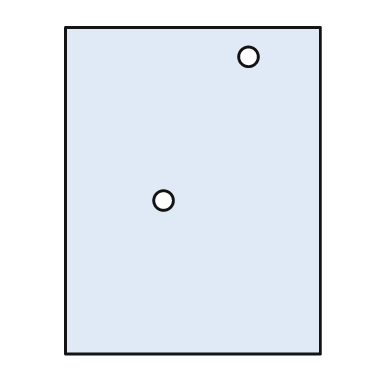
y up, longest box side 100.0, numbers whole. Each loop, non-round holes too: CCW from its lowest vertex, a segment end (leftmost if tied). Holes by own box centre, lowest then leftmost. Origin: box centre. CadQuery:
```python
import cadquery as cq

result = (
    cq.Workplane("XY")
    .moveTo(-39.0, -50.0)
    .lineTo(39.0, -50.0)
    .lineTo(39.0, 50.0)
    .lineTo(-39.0, 50.0)
    .close()
    .moveTo(-9.0, -3.0)
    .circle(3.0)
    .moveTo(17.0, 41.0)
    .circle(3.0)
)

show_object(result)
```